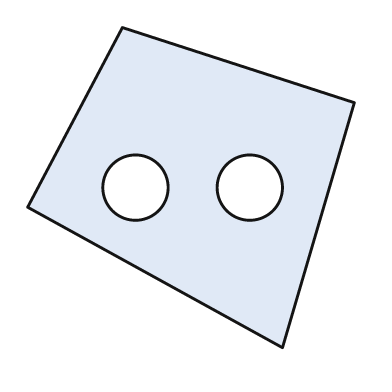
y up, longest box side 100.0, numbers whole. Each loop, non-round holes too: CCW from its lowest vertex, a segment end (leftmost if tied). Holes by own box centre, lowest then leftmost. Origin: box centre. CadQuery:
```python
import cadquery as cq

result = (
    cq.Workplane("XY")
    .moveTo(28.0, -49.0)
    .lineTo(50.0, 26.0)
    .lineTo(-21.0, 49.0)
    .lineTo(-50.0, -6.0)
    .close()
    .moveTo(-17.0, 0.0)
    .circle(10.0)
    .moveTo(18.0, 0.0)
    .circle(10.0)
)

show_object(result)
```